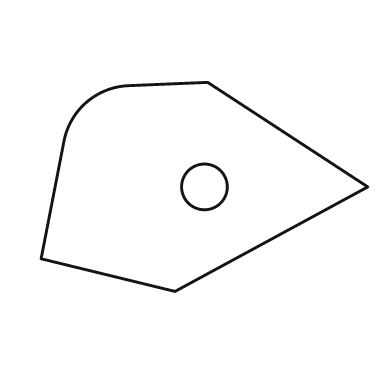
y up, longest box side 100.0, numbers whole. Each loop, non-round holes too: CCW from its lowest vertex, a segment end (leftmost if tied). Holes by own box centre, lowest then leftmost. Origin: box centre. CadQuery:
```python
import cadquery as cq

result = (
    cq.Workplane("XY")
    .moveTo(-9.0, -32.0)
    .lineTo(50.0, 0.0)
    .lineTo(1.0, 32.0)
    .lineTo(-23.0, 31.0)
    .threePointArc((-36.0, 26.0), (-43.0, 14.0))
    .lineTo(-50.0, -22.0)
    .close()
    .moveTo(0.0, 0.0)
    .circle(7.0)
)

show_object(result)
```